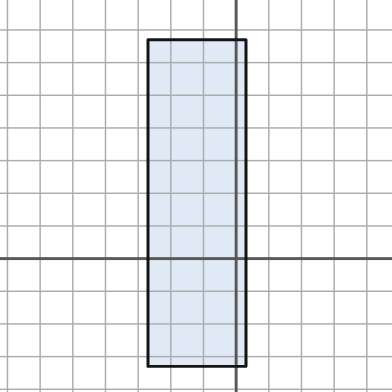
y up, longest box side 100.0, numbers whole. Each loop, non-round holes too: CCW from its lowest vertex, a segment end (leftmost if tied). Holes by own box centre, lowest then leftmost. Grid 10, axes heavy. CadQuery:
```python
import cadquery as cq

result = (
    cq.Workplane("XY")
    .moveTo(-27.0, -33.0)
    .lineTo(3.0, -33.0)
    .lineTo(3.0, 67.0)
    .lineTo(-27.0, 67.0)
    .close()
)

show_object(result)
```